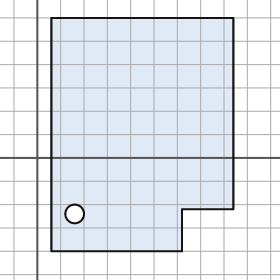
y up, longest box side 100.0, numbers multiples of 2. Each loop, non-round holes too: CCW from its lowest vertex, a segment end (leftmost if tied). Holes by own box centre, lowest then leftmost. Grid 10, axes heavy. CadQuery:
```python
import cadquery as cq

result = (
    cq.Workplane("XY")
    .moveTo(6.0, -40.0)
    .lineTo(62.0, -40.0)
    .lineTo(62.0, -22.0)
    .lineTo(84.0, -22.0)
    .lineTo(84.0, 60.0)
    .lineTo(6.0, 60.0)
    .close()
    .moveTo(16.0, -24.0)
    .circle(4.0)
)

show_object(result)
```